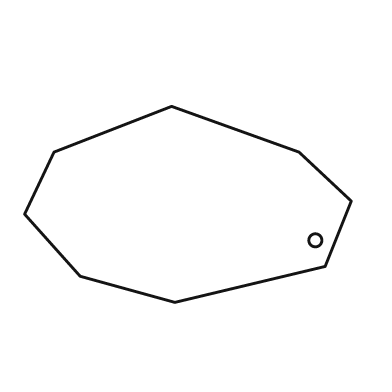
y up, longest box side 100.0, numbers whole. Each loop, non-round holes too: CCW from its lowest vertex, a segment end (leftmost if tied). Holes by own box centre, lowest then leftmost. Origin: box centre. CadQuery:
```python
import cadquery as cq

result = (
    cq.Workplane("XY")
    .moveTo(-4.0, -30.0)
    .lineTo(42.0, -19.0)
    .lineTo(50.0, 1.0)
    .lineTo(34.0, 16.0)
    .lineTo(-5.0, 30.0)
    .lineTo(-41.0, 16.0)
    .lineTo(-50.0, -3.0)
    .lineTo(-33.0, -22.0)
    .close()
    .moveTo(39.0, -11.0)
    .circle(2.0)
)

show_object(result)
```